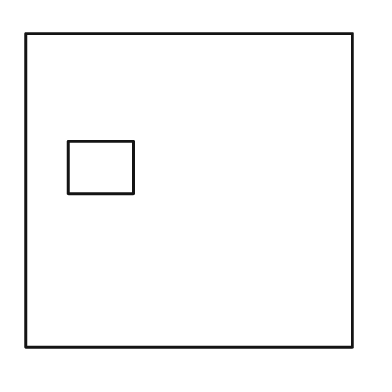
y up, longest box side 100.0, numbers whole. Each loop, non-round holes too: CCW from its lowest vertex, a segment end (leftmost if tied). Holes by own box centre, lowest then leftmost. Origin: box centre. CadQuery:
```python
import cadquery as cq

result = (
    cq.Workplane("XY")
    .moveTo(-50.0, -48.0)
    .lineTo(50.0, -48.0)
    .lineTo(50.0, 48.0)
    .lineTo(-50.0, 48.0)
    .close()
    .moveTo(-37.0, -1.0)
    .lineTo(-17.0, -1.0)
    .lineTo(-17.0, 15.0)
    .lineTo(-37.0, 15.0)
    .close()
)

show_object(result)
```